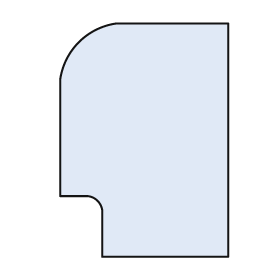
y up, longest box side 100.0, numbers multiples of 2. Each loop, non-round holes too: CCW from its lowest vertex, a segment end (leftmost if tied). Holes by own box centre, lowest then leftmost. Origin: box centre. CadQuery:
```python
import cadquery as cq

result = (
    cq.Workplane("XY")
    .moveTo(-18.0, -50.0)
    .lineTo(36.0, -50.0)
    .lineTo(36.0, 50.0)
    .lineTo(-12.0, 50.0)
    .threePointArc((-28.0, 42.0), (-36.0, 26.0))
    .lineTo(-36.0, -24.0)
    .lineTo(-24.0, -24.0)
    .threePointArc((-20.0, -26.0), (-18.0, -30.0))
    .close()
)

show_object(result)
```